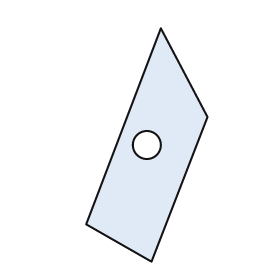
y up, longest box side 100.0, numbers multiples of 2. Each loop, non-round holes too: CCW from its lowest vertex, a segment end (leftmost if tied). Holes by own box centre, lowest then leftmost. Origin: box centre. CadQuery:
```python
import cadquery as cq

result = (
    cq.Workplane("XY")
    .moveTo(2.0, -50.0)
    .lineTo(26.0, 12.0)
    .lineTo(6.0, 50.0)
    .lineTo(-26.0, -34.0)
    .close()
    .moveTo(0.0, 0.0)
    .circle(6.0)
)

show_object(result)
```